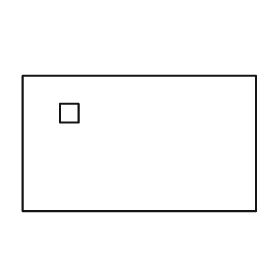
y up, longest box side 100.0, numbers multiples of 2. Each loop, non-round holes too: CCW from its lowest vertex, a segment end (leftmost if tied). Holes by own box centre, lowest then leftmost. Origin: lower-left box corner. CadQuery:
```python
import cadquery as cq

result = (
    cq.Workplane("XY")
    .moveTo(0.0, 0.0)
    .lineTo(100.0, 0.0)
    .lineTo(100.0, 58.0)
    .lineTo(0.0, 58.0)
    .close()
    .moveTo(16.0, 38.0)
    .lineTo(24.0, 38.0)
    .lineTo(24.0, 46.0)
    .lineTo(16.0, 46.0)
    .close()
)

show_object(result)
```